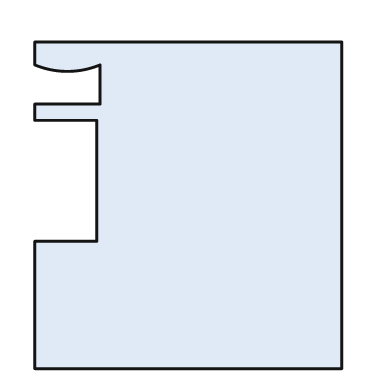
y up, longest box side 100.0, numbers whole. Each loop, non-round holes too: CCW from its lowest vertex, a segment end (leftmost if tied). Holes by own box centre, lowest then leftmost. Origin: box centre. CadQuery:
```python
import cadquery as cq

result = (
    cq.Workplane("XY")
    .moveTo(-47.0, -50.0)
    .lineTo(47.0, -50.0)
    .lineTo(47.0, 50.0)
    .lineTo(-47.0, 50.0)
    .lineTo(-47.0, 43.0)
    .threePointArc((-37.0, 41.0), (-27.0, 43.0))
    .lineTo(-27.0, 31.0)
    .lineTo(-47.0, 31.0)
    .lineTo(-47.0, 26.0)
    .lineTo(-28.0, 26.0)
    .lineTo(-28.0, -11.0)
    .lineTo(-47.0, -11.0)
    .close()
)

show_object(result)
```